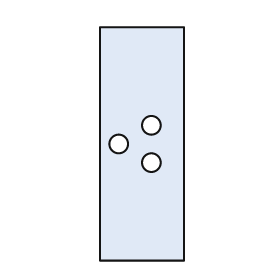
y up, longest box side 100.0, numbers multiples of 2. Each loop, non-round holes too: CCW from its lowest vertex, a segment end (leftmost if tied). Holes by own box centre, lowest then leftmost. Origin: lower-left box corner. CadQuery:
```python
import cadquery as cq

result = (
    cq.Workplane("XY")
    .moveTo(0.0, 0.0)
    .lineTo(36.0, 0.0)
    .lineTo(36.0, 100.0)
    .lineTo(0.0, 100.0)
    .close()
    .moveTo(22.0, 42.0)
    .circle(4.0)
    .moveTo(8.0, 50.0)
    .circle(4.0)
    .moveTo(22.0, 58.0)
    .circle(4.0)
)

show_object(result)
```